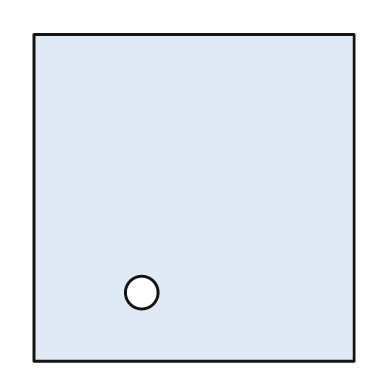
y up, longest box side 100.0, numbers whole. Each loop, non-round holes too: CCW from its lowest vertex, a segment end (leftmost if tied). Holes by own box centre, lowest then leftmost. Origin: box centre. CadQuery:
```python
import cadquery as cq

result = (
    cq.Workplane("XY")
    .moveTo(-49.0, -50.0)
    .lineTo(49.0, -50.0)
    .lineTo(49.0, 50.0)
    .lineTo(-49.0, 50.0)
    .close()
    .moveTo(-16.0, -29.0)
    .circle(5.0)
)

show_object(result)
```